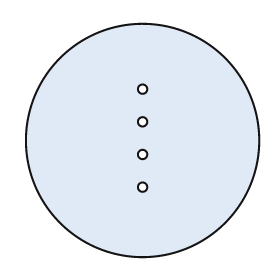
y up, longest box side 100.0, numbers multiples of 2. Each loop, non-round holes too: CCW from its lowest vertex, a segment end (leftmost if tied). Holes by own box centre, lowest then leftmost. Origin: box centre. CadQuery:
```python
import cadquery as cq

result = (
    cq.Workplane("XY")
    .moveTo(0.0, 0.0)
    .circle(50.0)
    .moveTo(0.0, -20.0)
    .circle(2.0)
    .moveTo(0.0, -6.0)
    .circle(2.0)
    .moveTo(0.0, 8.0)
    .circle(2.0)
    .moveTo(0.0, 22.0)
    .circle(2.0)
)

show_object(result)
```